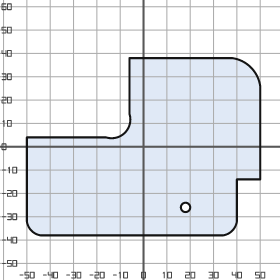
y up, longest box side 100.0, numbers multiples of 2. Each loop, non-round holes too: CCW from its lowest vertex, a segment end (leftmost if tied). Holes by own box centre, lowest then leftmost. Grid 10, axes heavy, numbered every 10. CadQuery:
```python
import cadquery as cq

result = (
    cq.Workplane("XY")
    .moveTo(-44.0, -38.0)
    .lineTo(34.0, -38.0)
    .threePointArc((38.0, -36.0), (40.0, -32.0))
    .lineTo(40.0, -14.0)
    .lineTo(50.0, -14.0)
    .lineTo(50.0, 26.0)
    .threePointArc((46.0, 34.0), (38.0, 38.0))
    .lineTo(-6.0, 38.0)
    .lineTo(-6.0, 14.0)
    .threePointArc((-8.0, 6.0), (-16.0, 4.0))
    .lineTo(-50.0, 4.0)
    .lineTo(-50.0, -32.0)
    .threePointArc((-48.0, -36.0), (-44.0, -38.0))
    .close()
    .moveTo(18.0, -26.0)
    .circle(2.0)
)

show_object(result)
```